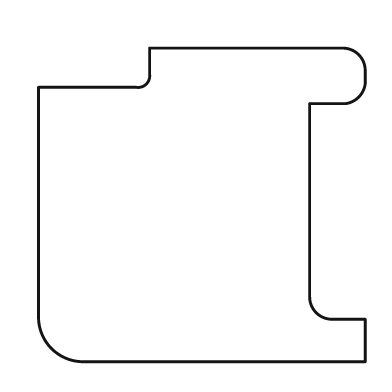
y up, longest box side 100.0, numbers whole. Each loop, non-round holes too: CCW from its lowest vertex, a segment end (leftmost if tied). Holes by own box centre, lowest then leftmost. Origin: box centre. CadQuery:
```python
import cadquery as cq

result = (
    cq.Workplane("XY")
    .moveTo(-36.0, -48.0)
    .lineTo(50.0, -48.0)
    .lineTo(50.0, -35.0)
    .lineTo(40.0, -35.0)
    .threePointArc((35.0, -33.0), (33.0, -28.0))
    .lineTo(33.0, 31.0)
    .lineTo(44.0, 31.0)
    .threePointArc((48.0, 33.0), (50.0, 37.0))
    .lineTo(50.0, 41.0)
    .threePointArc((48.0, 46.0), (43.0, 48.0))
    .lineTo(-16.0, 48.0)
    .lineTo(-16.0, 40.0)
    .threePointArc((-17.0, 37.0), (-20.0, 36.0))
    .lineTo(-50.0, 36.0)
    .lineTo(-50.0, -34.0)
    .threePointArc((-46.0, -44.0), (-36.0, -48.0))
    .close()
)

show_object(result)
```